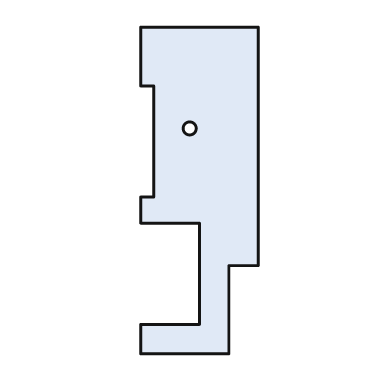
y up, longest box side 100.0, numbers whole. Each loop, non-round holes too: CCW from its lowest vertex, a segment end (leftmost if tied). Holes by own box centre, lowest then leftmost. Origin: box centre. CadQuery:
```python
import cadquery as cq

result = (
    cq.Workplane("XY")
    .moveTo(-18.0, -50.0)
    .lineTo(9.0, -50.0)
    .lineTo(9.0, -23.0)
    .lineTo(18.0, -23.0)
    .lineTo(18.0, 50.0)
    .lineTo(-18.0, 50.0)
    .lineTo(-18.0, 32.0)
    .lineTo(-14.0, 32.0)
    .lineTo(-14.0, -2.0)
    .lineTo(-18.0, -2.0)
    .lineTo(-18.0, -10.0)
    .lineTo(0.0, -10.0)
    .lineTo(0.0, -41.0)
    .lineTo(-18.0, -41.0)
    .close()
    .moveTo(-3.0, 19.0)
    .circle(2.0)
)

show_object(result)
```